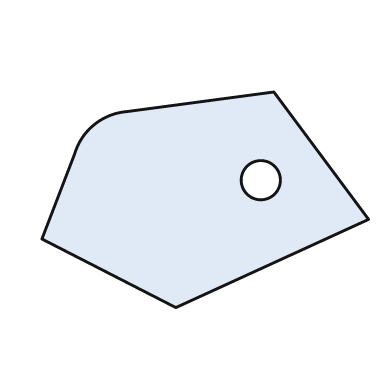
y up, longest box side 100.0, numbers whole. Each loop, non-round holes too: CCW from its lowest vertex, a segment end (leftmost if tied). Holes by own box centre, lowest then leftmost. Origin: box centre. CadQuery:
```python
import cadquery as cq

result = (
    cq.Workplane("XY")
    .moveTo(-9.0, -33.0)
    .lineTo(50.0, -6.0)
    .lineTo(21.0, 33.0)
    .lineTo(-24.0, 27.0)
    .threePointArc((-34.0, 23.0), (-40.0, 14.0))
    .lineTo(-50.0, -12.0)
    .close()
    .moveTo(17.0, 6.0)
    .circle(6.0)
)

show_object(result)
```